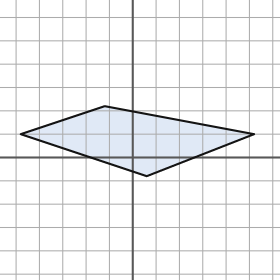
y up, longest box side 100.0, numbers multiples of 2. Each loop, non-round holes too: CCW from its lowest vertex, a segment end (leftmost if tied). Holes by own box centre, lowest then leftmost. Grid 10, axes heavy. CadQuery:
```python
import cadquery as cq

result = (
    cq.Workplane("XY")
    .moveTo(6.0, -8.0)
    .lineTo(52.0, 10.0)
    .lineTo(-12.0, 22.0)
    .lineTo(-48.0, 10.0)
    .close()
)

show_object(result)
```